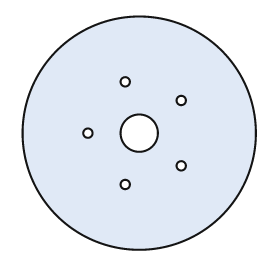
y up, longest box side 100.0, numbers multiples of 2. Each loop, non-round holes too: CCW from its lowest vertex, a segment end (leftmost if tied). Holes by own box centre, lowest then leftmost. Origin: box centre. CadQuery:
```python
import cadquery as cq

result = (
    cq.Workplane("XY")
    .moveTo(0.0, 0.0)
    .circle(50.0)
    .moveTo(-6.0, -22.0)
    .circle(2.0)
    .moveTo(18.0, -14.0)
    .circle(2.0)
    .moveTo(-22.0, 0.0)
    .circle(2.0)
    .moveTo(0.0, 0.0)
    .circle(8.0)
    .moveTo(18.0, 14.0)
    .circle(2.0)
    .moveTo(-6.0, 22.0)
    .circle(2.0)
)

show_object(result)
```